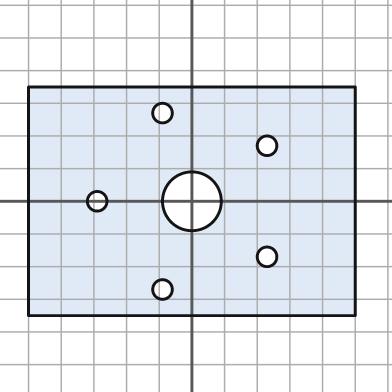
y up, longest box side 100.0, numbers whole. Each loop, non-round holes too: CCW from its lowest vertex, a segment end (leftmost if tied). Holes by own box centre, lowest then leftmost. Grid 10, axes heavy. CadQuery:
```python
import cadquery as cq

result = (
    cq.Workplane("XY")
    .moveTo(-50.0, -35.0)
    .lineTo(50.0, -35.0)
    .lineTo(50.0, 35.0)
    .lineTo(-50.0, 35.0)
    .close()
    .moveTo(-9.0, -27.0)
    .circle(3.0)
    .moveTo(23.0, -17.0)
    .circle(3.0)
    .moveTo(-29.0, 0.0)
    .circle(3.0)
    .moveTo(0.0, 0.0)
    .circle(9.0)
    .moveTo(23.0, 17.0)
    .circle(3.0)
    .moveTo(-9.0, 27.0)
    .circle(3.0)
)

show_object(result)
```